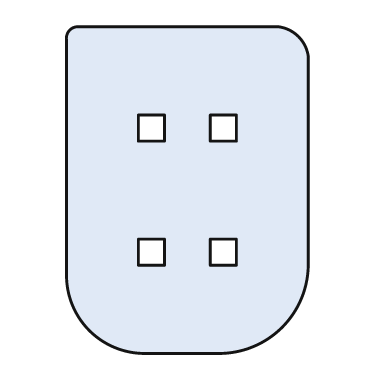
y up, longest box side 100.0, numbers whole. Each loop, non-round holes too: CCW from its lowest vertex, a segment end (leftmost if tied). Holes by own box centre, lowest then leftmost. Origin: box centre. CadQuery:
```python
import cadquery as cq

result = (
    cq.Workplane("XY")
    .moveTo(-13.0, -50.0)
    .lineTo(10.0, -50.0)
    .threePointArc((29.0, -42.0), (37.0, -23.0))
    .lineTo(37.0, 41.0)
    .threePointArc((34.0, 47.0), (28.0, 50.0))
    .lineTo(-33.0, 50.0)
    .threePointArc((-36.0, 49.0), (-37.0, 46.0))
    .lineTo(-37.0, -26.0)
    .threePointArc((-30.0, -43.0), (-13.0, -50.0))
    .close()
    .moveTo(-15.0, -23.0)
    .lineTo(-7.0, -23.0)
    .lineTo(-7.0, -15.0)
    .lineTo(-15.0, -15.0)
    .close()
    .moveTo(7.0, -23.0)
    .lineTo(15.0, -23.0)
    .lineTo(15.0, -15.0)
    .lineTo(7.0, -15.0)
    .close()
    .moveTo(-15.0, 15.0)
    .lineTo(-7.0, 15.0)
    .lineTo(-7.0, 23.0)
    .lineTo(-15.0, 23.0)
    .close()
    .moveTo(7.0, 15.0)
    .lineTo(15.0, 15.0)
    .lineTo(15.0, 23.0)
    .lineTo(7.0, 23.0)
    .close()
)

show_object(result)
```